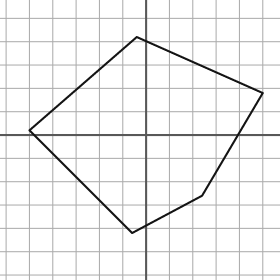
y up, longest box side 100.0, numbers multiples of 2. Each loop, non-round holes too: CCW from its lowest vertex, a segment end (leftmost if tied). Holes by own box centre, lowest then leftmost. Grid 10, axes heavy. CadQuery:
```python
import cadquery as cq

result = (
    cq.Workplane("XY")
    .moveTo(-6.0, -42.0)
    .lineTo(24.0, -26.0)
    .lineTo(50.0, 18.0)
    .lineTo(-4.0, 42.0)
    .lineTo(-50.0, 2.0)
    .close()
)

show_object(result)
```